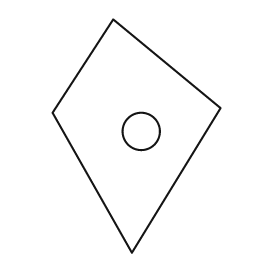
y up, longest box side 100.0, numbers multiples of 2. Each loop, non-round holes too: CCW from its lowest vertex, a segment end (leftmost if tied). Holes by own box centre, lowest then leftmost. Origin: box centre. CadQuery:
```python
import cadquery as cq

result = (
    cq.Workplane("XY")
    .moveTo(-2.0, -50.0)
    .lineTo(36.0, 12.0)
    .lineTo(-10.0, 50.0)
    .lineTo(-36.0, 10.0)
    .close()
    .moveTo(2.0, 2.0)
    .circle(8.0)
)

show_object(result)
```